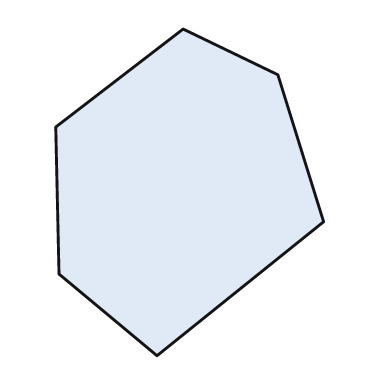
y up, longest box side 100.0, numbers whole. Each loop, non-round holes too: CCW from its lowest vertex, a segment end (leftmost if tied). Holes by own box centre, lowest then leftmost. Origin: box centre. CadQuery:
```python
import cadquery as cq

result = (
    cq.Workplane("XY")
    .moveTo(-10.0, -50.0)
    .lineTo(41.0, -9.0)
    .lineTo(27.0, 36.0)
    .lineTo(-2.0, 50.0)
    .lineTo(-41.0, 20.0)
    .lineTo(-40.0, -25.0)
    .close()
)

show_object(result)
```